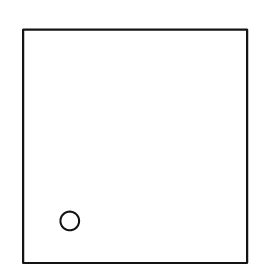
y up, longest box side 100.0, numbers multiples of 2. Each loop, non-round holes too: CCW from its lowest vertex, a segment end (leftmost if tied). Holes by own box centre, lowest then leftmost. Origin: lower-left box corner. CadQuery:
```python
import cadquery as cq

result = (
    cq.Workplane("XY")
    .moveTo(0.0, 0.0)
    .lineTo(96.0, 0.0)
    .lineTo(96.0, 100.0)
    .lineTo(0.0, 100.0)
    .close()
    .moveTo(20.0, 18.0)
    .circle(4.0)
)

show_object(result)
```